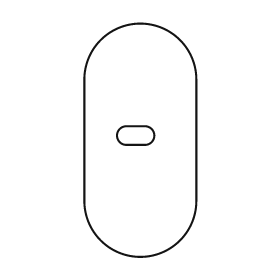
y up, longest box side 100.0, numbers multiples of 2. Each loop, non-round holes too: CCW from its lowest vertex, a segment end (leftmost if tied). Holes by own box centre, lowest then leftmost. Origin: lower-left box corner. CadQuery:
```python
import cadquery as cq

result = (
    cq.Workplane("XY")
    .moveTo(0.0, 24.0)
    .threePointArc((24.0, 0.0), (48.0, 24.0))
    .lineTo(48.0, 76.0)
    .threePointArc((24.0, 100.0), (0.0, 76.0))
    .close()
    .moveTo(18.0, 48.0)
    .lineTo(26.0, 48.0)
    .threePointArc((30.0, 52.0), (26.0, 56.0))
    .lineTo(18.0, 56.0)
    .threePointArc((14.0, 52.0), (18.0, 48.0))
    .close()
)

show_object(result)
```